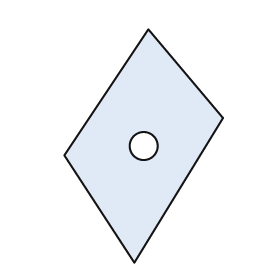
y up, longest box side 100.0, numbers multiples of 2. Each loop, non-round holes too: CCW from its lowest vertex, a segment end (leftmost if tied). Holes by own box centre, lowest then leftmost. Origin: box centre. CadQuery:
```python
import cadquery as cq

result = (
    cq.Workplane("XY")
    .moveTo(-4.0, -50.0)
    .lineTo(34.0, 12.0)
    .lineTo(2.0, 50.0)
    .lineTo(-34.0, -4.0)
    .close()
    .moveTo(0.0, 0.0)
    .circle(6.0)
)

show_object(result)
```